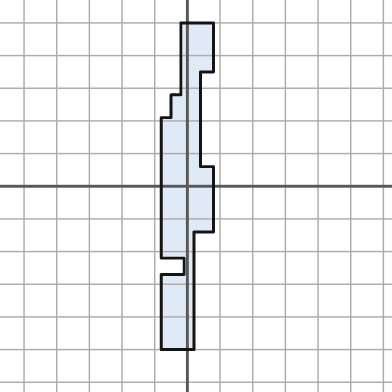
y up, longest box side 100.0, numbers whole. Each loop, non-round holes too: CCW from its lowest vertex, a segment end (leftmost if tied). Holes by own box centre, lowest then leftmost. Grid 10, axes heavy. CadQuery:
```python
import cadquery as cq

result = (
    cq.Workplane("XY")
    .moveTo(-8.0, -50.0)
    .lineTo(2.0, -50.0)
    .lineTo(2.0, -14.0)
    .lineTo(8.0, -14.0)
    .lineTo(8.0, 6.0)
    .lineTo(4.0, 6.0)
    .lineTo(4.0, 35.0)
    .lineTo(8.0, 35.0)
    .lineTo(8.0, 50.0)
    .lineTo(-2.0, 50.0)
    .lineTo(-2.0, 28.0)
    .lineTo(-5.0, 28.0)
    .lineTo(-5.0, 21.0)
    .lineTo(-8.0, 21.0)
    .lineTo(-8.0, -22.0)
    .lineTo(-1.0, -22.0)
    .lineTo(-1.0, -27.0)
    .lineTo(-8.0, -27.0)
    .close()
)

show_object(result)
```